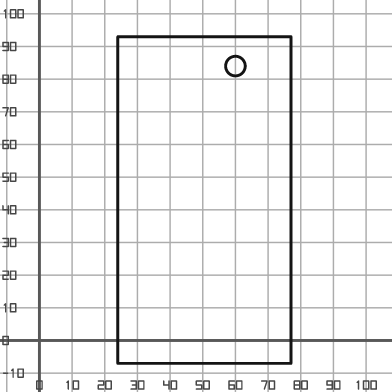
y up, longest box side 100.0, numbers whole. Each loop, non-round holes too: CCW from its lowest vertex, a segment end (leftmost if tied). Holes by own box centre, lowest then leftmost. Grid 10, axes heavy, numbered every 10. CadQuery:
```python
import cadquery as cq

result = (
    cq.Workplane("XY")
    .moveTo(24.0, -7.0)
    .lineTo(77.0, -7.0)
    .lineTo(77.0, 93.0)
    .lineTo(24.0, 93.0)
    .close()
    .moveTo(60.0, 84.0)
    .circle(3.0)
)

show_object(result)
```